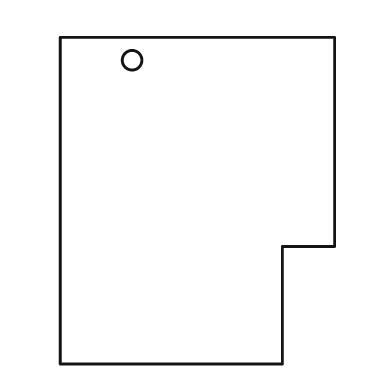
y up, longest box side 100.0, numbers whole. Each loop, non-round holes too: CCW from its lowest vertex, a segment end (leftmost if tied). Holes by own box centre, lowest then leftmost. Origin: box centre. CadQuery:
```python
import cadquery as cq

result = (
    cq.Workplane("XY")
    .moveTo(-42.0, -50.0)
    .lineTo(26.0, -50.0)
    .lineTo(26.0, -14.0)
    .lineTo(42.0, -14.0)
    .lineTo(42.0, 50.0)
    .lineTo(-42.0, 50.0)
    .close()
    .moveTo(-20.0, 43.0)
    .circle(3.0)
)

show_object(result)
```